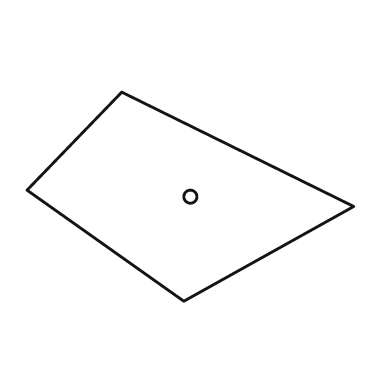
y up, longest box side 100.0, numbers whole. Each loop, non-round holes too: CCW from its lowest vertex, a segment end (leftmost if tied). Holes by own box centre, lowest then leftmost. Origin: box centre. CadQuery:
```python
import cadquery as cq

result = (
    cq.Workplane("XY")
    .moveTo(-2.0, -32.0)
    .lineTo(50.0, -3.0)
    .lineTo(-21.0, 32.0)
    .lineTo(-50.0, 2.0)
    .close()
    .moveTo(0.0, 0.0)
    .circle(2.0)
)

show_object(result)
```